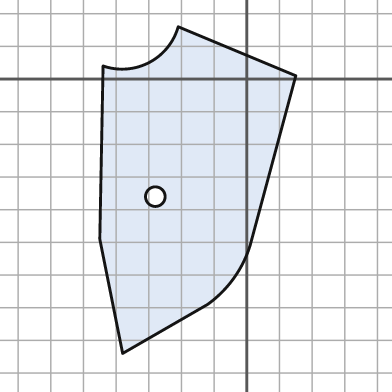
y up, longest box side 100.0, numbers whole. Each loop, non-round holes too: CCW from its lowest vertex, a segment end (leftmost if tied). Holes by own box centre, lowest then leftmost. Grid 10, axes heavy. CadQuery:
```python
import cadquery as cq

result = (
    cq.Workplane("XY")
    .moveTo(-38.0, -84.0)
    .lineTo(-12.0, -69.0)
    .threePointArc((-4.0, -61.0), (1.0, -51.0))
    .lineTo(15.0, 1.0)
    .lineTo(-21.0, 16.0)
    .threePointArc((-30.0, 5.0), (-44.0, 4.0))
    .lineTo(-45.0, -49.0)
    .close()
    .moveTo(-28.0, -36.0)
    .circle(3.0)
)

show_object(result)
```